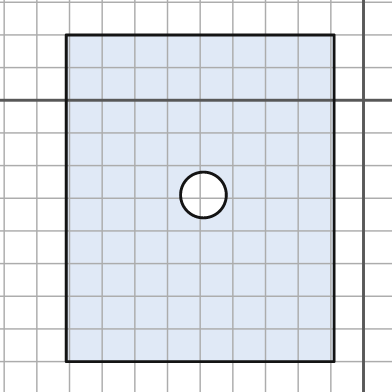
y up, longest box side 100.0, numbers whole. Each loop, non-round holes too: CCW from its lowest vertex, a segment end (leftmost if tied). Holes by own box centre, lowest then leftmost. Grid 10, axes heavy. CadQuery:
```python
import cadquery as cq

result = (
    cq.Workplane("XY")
    .moveTo(-91.0, -80.0)
    .lineTo(-9.0, -80.0)
    .lineTo(-9.0, 20.0)
    .lineTo(-91.0, 20.0)
    .close()
    .moveTo(-49.0, -29.0)
    .circle(7.0)
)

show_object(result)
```